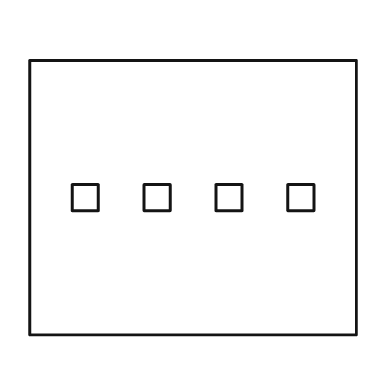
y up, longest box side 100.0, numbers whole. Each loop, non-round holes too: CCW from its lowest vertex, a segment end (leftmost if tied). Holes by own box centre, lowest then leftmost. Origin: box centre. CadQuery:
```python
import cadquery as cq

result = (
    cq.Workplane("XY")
    .moveTo(-50.0, -42.0)
    .lineTo(50.0, -42.0)
    .lineTo(50.0, 42.0)
    .lineTo(-50.0, 42.0)
    .close()
    .moveTo(-37.0, -4.0)
    .lineTo(-29.0, -4.0)
    .lineTo(-29.0, 4.0)
    .lineTo(-37.0, 4.0)
    .close()
    .moveTo(-15.0, -4.0)
    .lineTo(-7.0, -4.0)
    .lineTo(-7.0, 4.0)
    .lineTo(-15.0, 4.0)
    .close()
    .moveTo(7.0, -4.0)
    .lineTo(15.0, -4.0)
    .lineTo(15.0, 4.0)
    .lineTo(7.0, 4.0)
    .close()
    .moveTo(29.0, -4.0)
    .lineTo(37.0, -4.0)
    .lineTo(37.0, 4.0)
    .lineTo(29.0, 4.0)
    .close()
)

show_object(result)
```